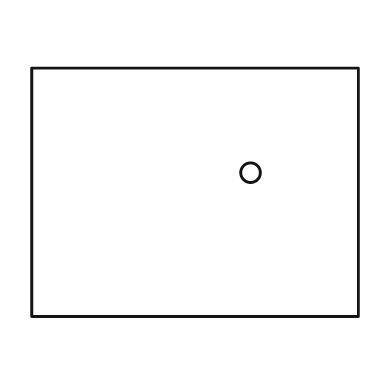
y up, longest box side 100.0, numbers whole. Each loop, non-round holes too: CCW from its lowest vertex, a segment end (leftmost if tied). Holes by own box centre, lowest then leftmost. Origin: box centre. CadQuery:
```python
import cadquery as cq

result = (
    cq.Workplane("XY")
    .moveTo(-50.0, -38.0)
    .lineTo(50.0, -38.0)
    .lineTo(50.0, 38.0)
    .lineTo(-50.0, 38.0)
    .close()
    .moveTo(17.0, 6.0)
    .circle(3.0)
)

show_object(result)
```